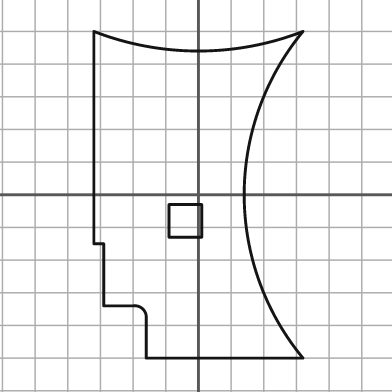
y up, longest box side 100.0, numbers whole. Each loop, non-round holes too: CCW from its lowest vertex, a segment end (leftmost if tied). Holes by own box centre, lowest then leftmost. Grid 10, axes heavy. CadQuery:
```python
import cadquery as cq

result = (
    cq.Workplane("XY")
    .moveTo(-16.0, -50.0)
    .lineTo(32.0, -50.0)
    .threePointArc((14.0, 0.0), (32.0, 50.0))
    .threePointArc((0.0, 44.0), (-32.0, 50.0))
    .lineTo(-32.0, -15.0)
    .lineTo(-29.0, -15.0)
    .lineTo(-29.0, -34.0)
    .lineTo(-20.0, -34.0)
    .threePointArc((-17.0, -35.0), (-16.0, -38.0))
    .close()
    .moveTo(-9.0, -13.0)
    .lineTo(1.0, -13.0)
    .lineTo(1.0, -3.0)
    .lineTo(-9.0, -3.0)
    .close()
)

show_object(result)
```